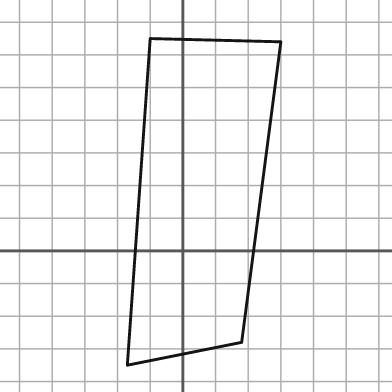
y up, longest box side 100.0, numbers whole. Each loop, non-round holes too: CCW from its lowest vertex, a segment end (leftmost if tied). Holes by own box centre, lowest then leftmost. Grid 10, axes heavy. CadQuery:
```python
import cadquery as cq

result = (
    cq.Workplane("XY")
    .moveTo(-17.0, -35.0)
    .lineTo(18.0, -28.0)
    .lineTo(30.0, 64.0)
    .lineTo(-10.0, 65.0)
    .close()
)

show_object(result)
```